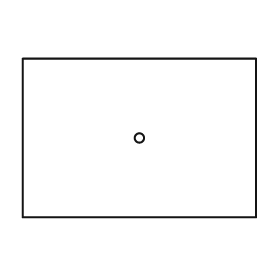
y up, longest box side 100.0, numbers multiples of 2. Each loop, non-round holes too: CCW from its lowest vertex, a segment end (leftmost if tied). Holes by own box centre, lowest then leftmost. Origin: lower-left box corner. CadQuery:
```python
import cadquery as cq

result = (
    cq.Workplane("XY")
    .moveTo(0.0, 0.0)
    .lineTo(100.0, 0.0)
    .lineTo(100.0, 68.0)
    .lineTo(0.0, 68.0)
    .close()
    .moveTo(50.0, 34.0)
    .circle(2.0)
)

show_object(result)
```